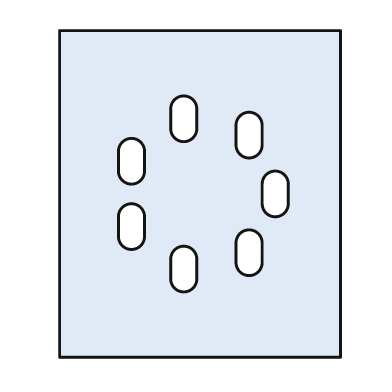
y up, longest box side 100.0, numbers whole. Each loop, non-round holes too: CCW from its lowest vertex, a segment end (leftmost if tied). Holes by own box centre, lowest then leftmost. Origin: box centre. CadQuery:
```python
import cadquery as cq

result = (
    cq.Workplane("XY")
    .moveTo(-43.0, -50.0)
    .lineTo(43.0, -50.0)
    .lineTo(43.0, 50.0)
    .lineTo(-43.0, 50.0)
    .close()
    .moveTo(-9.0, -26.0)
    .threePointArc((-5.0, -30.0), (-1.0, -26.0))
    .lineTo(-1.0, -20.0)
    .threePointArc((-5.0, -16.0), (-9.0, -20.0))
    .close()
    .moveTo(11.0, -21.0)
    .threePointArc((15.0, -25.0), (19.0, -21.0))
    .lineTo(19.0, -15.0)
    .threePointArc((15.0, -11.0), (11.0, -15.0))
    .close()
    .moveTo(-25.0, -13.0)
    .threePointArc((-21.0, -17.0), (-17.0, -13.0))
    .lineTo(-17.0, -7.0)
    .threePointArc((-21.0, -3.0), (-25.0, -7.0))
    .close()
    .moveTo(19.0, -3.0)
    .threePointArc((23.0, -7.0), (27.0, -3.0))
    .lineTo(27.0, 3.0)
    .threePointArc((23.0, 7.0), (19.0, 3.0))
    .close()
    .moveTo(-25.0, 7.0)
    .threePointArc((-21.0, 3.0), (-17.0, 7.0))
    .lineTo(-17.0, 13.0)
    .threePointArc((-21.0, 17.0), (-25.0, 13.0))
    .close()
    .moveTo(11.0, 15.0)
    .threePointArc((15.0, 11.0), (19.0, 15.0))
    .lineTo(19.0, 21.0)
    .threePointArc((15.0, 25.0), (11.0, 21.0))
    .close()
    .moveTo(-9.0, 20.0)
    .threePointArc((-5.0, 16.0), (-1.0, 20.0))
    .lineTo(-1.0, 26.0)
    .threePointArc((-5.0, 30.0), (-9.0, 26.0))
    .close()
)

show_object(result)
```